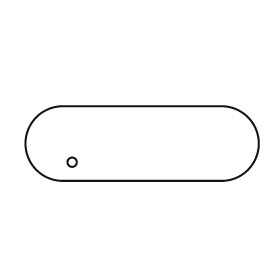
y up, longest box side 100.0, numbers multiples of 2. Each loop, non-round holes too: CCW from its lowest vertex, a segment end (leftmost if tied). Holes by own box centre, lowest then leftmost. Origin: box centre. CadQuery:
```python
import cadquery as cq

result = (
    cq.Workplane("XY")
    .moveTo(-34.0, -16.0)
    .lineTo(34.0, -16.0)
    .threePointArc((50.0, 0.0), (34.0, 16.0))
    .lineTo(-34.0, 16.0)
    .threePointArc((-50.0, 0.0), (-34.0, -16.0))
    .close()
    .moveTo(-30.0, -8.0)
    .circle(2.0)
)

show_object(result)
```